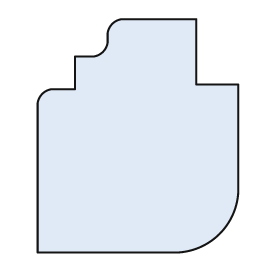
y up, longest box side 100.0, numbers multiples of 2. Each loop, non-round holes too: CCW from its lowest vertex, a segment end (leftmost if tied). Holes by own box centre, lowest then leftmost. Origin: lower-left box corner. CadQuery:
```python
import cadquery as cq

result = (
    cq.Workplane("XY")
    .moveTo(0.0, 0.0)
    .lineTo(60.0, 0.0)
    .threePointArc((78.0, 8.0), (86.0, 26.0))
    .lineTo(86.0, 72.0)
    .lineTo(68.0, 72.0)
    .lineTo(68.0, 100.0)
    .lineTo(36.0, 100.0)
    .threePointArc((32.0, 98.0), (30.0, 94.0))
    .lineTo(30.0, 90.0)
    .threePointArc((28.0, 86.0), (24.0, 84.0))
    .lineTo(16.0, 84.0)
    .lineTo(16.0, 70.0)
    .lineTo(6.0, 70.0)
    .threePointArc((2.0, 68.0), (0.0, 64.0))
    .close()
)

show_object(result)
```